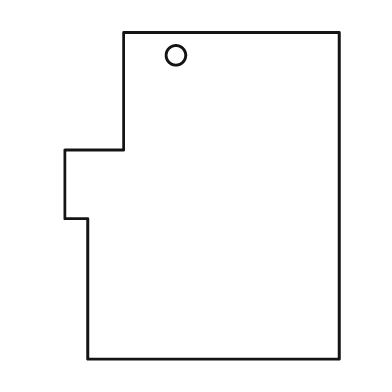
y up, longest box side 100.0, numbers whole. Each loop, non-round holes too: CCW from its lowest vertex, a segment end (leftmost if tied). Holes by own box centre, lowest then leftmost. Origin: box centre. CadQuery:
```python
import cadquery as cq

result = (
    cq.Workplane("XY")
    .moveTo(-35.0, -50.0)
    .lineTo(42.0, -50.0)
    .lineTo(42.0, 50.0)
    .lineTo(-24.0, 50.0)
    .lineTo(-24.0, 14.0)
    .lineTo(-42.0, 14.0)
    .lineTo(-42.0, -7.0)
    .lineTo(-35.0, -7.0)
    .close()
    .moveTo(-8.0, 43.0)
    .circle(3.0)
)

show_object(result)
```